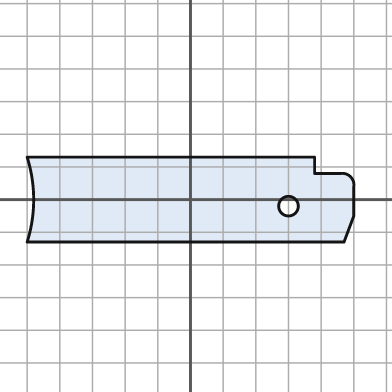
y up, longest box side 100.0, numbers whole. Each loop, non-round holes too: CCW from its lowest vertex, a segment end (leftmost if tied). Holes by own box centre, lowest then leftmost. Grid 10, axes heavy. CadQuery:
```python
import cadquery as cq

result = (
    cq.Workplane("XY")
    .moveTo(-50.0, -13.0)
    .lineTo(47.0, -13.0)
    .lineTo(50.0, -5.0)
    .lineTo(50.0, 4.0)
    .threePointArc((49.0, 7.0), (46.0, 8.0))
    .lineTo(38.0, 8.0)
    .lineTo(38.0, 13.0)
    .lineTo(-50.0, 13.0)
    .threePointArc((-48.0, 0.0), (-50.0, -13.0))
    .close()
    .moveTo(30.0, -2.0)
    .circle(3.0)
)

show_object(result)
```